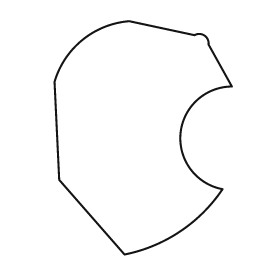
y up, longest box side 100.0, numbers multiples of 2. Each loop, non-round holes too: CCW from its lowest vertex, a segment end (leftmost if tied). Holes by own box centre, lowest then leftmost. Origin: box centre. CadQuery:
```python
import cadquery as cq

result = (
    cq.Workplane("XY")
    .moveTo(-8.0, -50.0)
    .threePointArc((16.0, -40.0), (34.0, -22.0))
    .threePointArc((16.0, 2.0), (38.0, 22.0))
    .lineTo(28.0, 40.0)
    .threePointArc((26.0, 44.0), (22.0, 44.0))
    .lineTo(-6.0, 50.0)
    .threePointArc((-26.0, 42.0), (-38.0, 24.0))
    .lineTo(-36.0, -18.0)
    .close()
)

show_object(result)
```